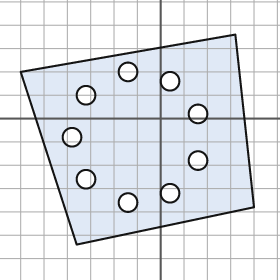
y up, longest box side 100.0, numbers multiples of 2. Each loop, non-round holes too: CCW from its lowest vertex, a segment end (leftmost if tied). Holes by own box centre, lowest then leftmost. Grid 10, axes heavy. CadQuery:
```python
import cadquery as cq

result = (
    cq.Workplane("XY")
    .moveTo(-36.0, -54.0)
    .lineTo(40.0, -38.0)
    .lineTo(32.0, 36.0)
    .lineTo(-60.0, 20.0)
    .close()
    .moveTo(-14.0, -36.0)
    .circle(4.0)
    .moveTo(4.0, -32.0)
    .circle(4.0)
    .moveTo(-32.0, -26.0)
    .circle(4.0)
    .moveTo(16.0, -18.0)
    .circle(4.0)
    .moveTo(-38.0, -8.0)
    .circle(4.0)
    .moveTo(16.0, 2.0)
    .circle(4.0)
    .moveTo(-32.0, 10.0)
    .circle(4.0)
    .moveTo(4.0, 16.0)
    .circle(4.0)
    .moveTo(-14.0, 20.0)
    .circle(4.0)
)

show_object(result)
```